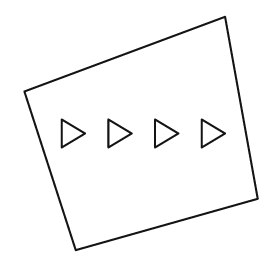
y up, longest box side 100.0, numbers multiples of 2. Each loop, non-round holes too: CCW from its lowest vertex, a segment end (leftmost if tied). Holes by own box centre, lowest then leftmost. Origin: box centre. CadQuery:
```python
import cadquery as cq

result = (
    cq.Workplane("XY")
    .moveTo(-28.0, -50.0)
    .lineTo(50.0, -28.0)
    .lineTo(36.0, 50.0)
    .lineTo(-50.0, 18.0)
    .close()
    .moveTo(-34.0, -6.0)
    .lineTo(-24.0, 0.0)
    .lineTo(-34.0, 6.0)
    .close()
    .moveTo(-14.0, -6.0)
    .lineTo(-4.0, 0.0)
    .lineTo(-14.0, 6.0)
    .close()
    .moveTo(6.0, -6.0)
    .lineTo(16.0, 0.0)
    .lineTo(6.0, 6.0)
    .close()
    .moveTo(26.0, -6.0)
    .lineTo(36.0, 0.0)
    .lineTo(26.0, 6.0)
    .close()
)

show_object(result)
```